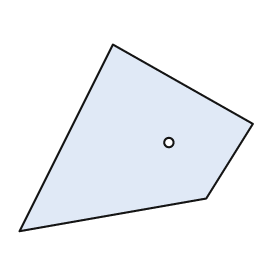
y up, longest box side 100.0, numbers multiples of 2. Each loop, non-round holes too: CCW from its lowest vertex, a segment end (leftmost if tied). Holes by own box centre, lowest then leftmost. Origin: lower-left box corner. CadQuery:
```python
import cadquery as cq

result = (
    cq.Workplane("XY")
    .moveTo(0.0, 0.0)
    .lineTo(80.0, 14.0)
    .lineTo(100.0, 46.0)
    .lineTo(40.0, 80.0)
    .close()
    .moveTo(64.0, 38.0)
    .circle(2.0)
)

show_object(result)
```